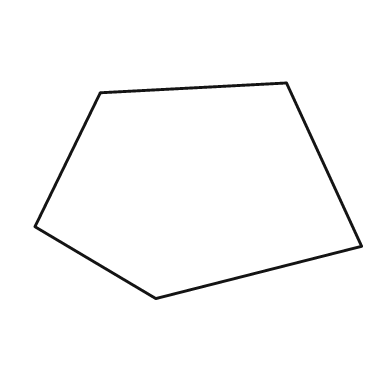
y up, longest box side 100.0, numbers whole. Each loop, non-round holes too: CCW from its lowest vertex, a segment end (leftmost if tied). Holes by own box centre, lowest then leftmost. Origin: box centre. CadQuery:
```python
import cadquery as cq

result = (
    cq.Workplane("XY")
    .moveTo(-13.0, -33.0)
    .lineTo(50.0, -17.0)
    .lineTo(27.0, 33.0)
    .lineTo(-30.0, 30.0)
    .lineTo(-50.0, -11.0)
    .close()
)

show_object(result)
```